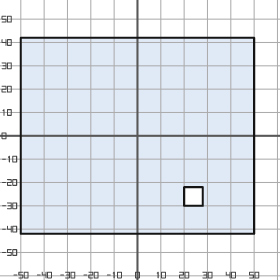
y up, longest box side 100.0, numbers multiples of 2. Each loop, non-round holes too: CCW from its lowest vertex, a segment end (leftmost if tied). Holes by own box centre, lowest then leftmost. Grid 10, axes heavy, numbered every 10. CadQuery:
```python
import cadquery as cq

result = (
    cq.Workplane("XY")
    .moveTo(-50.0, -42.0)
    .lineTo(50.0, -42.0)
    .lineTo(50.0, 42.0)
    .lineTo(-50.0, 42.0)
    .close()
    .moveTo(20.0, -30.0)
    .lineTo(28.0, -30.0)
    .lineTo(28.0, -22.0)
    .lineTo(20.0, -22.0)
    .close()
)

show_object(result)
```